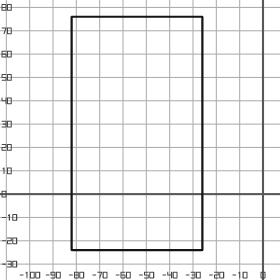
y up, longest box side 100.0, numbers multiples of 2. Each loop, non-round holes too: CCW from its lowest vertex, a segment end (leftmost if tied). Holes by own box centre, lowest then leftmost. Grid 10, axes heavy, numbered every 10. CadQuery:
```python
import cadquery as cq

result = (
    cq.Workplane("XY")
    .moveTo(-82.0, -24.0)
    .lineTo(-26.0, -24.0)
    .lineTo(-26.0, 76.0)
    .lineTo(-82.0, 76.0)
    .close()
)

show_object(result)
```